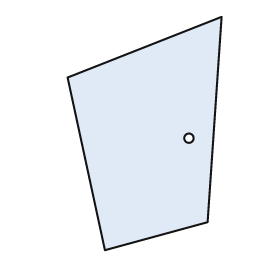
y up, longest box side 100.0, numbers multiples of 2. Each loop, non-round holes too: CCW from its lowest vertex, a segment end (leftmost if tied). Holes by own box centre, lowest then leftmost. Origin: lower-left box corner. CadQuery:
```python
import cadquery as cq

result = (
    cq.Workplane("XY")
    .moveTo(16.0, 0.0)
    .lineTo(60.0, 12.0)
    .lineTo(66.0, 100.0)
    .lineTo(0.0, 74.0)
    .close()
    .moveTo(52.0, 48.0)
    .circle(2.0)
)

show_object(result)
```